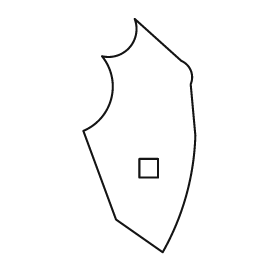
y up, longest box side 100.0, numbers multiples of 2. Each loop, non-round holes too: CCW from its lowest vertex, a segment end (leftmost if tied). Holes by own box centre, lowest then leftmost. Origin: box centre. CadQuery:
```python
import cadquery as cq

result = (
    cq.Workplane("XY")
    .moveTo(10.0, -50.0)
    .threePointArc((20.0, -26.0), (24.0, 0.0))
    .lineTo(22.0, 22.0)
    .threePointArc((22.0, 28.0), (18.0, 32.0))
    .lineTo(-2.0, 50.0)
    .threePointArc((-4.0, 38.0), (-16.0, 34.0))
    .threePointArc((-12.0, 16.0), (-24.0, 2.0))
    .lineTo(-10.0, -36.0)
    .close()
    .moveTo(0.0, -18.0)
    .lineTo(8.0, -18.0)
    .lineTo(8.0, -10.0)
    .lineTo(0.0, -10.0)
    .close()
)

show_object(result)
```